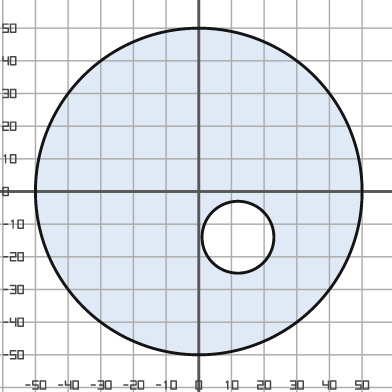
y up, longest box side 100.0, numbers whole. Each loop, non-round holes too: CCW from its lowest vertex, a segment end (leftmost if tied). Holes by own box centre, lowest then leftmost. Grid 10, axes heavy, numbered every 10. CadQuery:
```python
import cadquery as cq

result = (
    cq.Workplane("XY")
    .moveTo(0.0, 0.0)
    .circle(50.0)
    .moveTo(12.0, -14.0)
    .circle(11.0)
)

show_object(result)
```